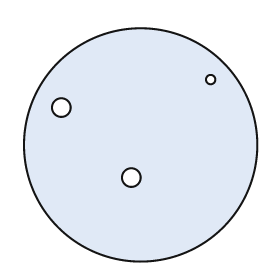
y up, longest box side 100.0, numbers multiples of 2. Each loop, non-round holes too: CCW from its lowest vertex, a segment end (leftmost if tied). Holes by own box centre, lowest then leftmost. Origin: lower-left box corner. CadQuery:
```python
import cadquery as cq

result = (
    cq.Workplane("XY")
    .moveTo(50.0, 50.0)
    .circle(50.0)
    .moveTo(46.0, 36.0)
    .circle(4.0)
    .moveTo(16.0, 66.0)
    .circle(4.0)
    .moveTo(80.0, 78.0)
    .circle(2.0)
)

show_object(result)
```